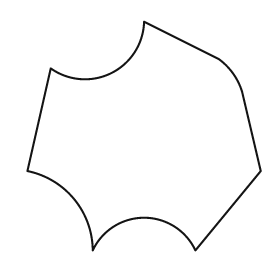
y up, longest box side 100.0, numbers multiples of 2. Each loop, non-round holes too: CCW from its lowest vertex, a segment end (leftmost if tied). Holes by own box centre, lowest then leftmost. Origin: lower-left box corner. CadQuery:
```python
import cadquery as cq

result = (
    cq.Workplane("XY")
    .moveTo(28.0, 0.0)
    .threePointArc((50.0, 14.0), (72.0, 0.0))
    .lineTo(100.0, 34.0)
    .lineTo(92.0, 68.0)
    .threePointArc((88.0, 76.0), (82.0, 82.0))
    .lineTo(50.0, 98.0)
    .threePointArc((36.0, 76.0), (10.0, 78.0))
    .lineTo(0.0, 34.0)
    .threePointArc((20.0, 22.0), (28.0, 0.0))
    .close()
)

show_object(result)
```